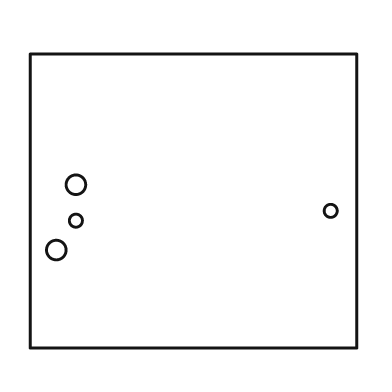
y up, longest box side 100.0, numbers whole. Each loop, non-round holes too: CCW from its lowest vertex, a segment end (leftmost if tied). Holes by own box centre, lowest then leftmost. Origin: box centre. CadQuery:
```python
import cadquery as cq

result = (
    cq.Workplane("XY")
    .moveTo(-50.0, -45.0)
    .lineTo(50.0, -45.0)
    .lineTo(50.0, 45.0)
    .lineTo(-50.0, 45.0)
    .close()
    .moveTo(-42.0, -15.0)
    .circle(3.0)
    .moveTo(-36.0, -6.0)
    .circle(2.0)
    .moveTo(42.0, -3.0)
    .circle(2.0)
    .moveTo(-36.0, 5.0)
    .circle(3.0)
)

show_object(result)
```